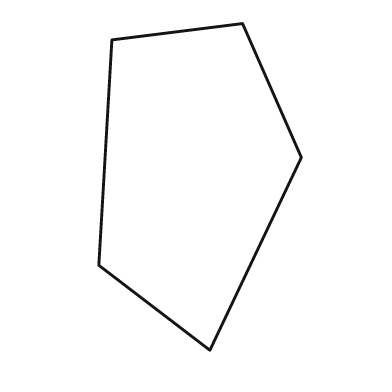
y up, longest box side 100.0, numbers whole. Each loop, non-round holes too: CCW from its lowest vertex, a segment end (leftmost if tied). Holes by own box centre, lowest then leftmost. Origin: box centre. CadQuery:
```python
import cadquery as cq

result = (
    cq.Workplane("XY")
    .moveTo(3.0, -50.0)
    .lineTo(31.0, 9.0)
    .lineTo(13.0, 50.0)
    .lineTo(-27.0, 45.0)
    .lineTo(-31.0, -24.0)
    .close()
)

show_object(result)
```